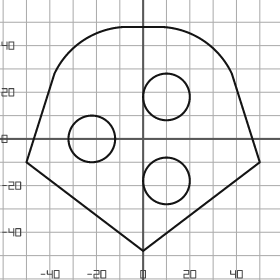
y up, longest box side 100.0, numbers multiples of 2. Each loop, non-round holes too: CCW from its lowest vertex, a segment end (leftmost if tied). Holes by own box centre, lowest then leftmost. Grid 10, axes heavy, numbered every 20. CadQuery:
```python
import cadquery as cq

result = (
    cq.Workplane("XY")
    .moveTo(0.0, -48.0)
    .lineTo(50.0, -10.0)
    .lineTo(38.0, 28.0)
    .threePointArc((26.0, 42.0), (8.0, 48.0))
    .lineTo(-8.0, 48.0)
    .threePointArc((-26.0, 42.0), (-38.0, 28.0))
    .lineTo(-50.0, -10.0)
    .close()
    .moveTo(10.0, -18.0)
    .circle(10.0)
    .moveTo(-22.0, 0.0)
    .circle(10.0)
    .moveTo(10.0, 18.0)
    .circle(10.0)
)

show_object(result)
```